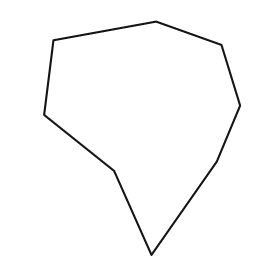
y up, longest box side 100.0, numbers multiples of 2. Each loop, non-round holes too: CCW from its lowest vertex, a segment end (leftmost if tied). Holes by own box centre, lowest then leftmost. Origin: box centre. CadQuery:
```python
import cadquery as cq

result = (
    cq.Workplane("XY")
    .moveTo(4.0, -50.0)
    .lineTo(32.0, -10.0)
    .lineTo(42.0, 14.0)
    .lineTo(34.0, 40.0)
    .lineTo(6.0, 50.0)
    .lineTo(-38.0, 42.0)
    .lineTo(-42.0, 10.0)
    .lineTo(-12.0, -14.0)
    .close()
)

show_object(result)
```